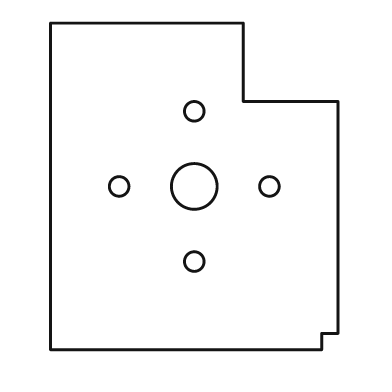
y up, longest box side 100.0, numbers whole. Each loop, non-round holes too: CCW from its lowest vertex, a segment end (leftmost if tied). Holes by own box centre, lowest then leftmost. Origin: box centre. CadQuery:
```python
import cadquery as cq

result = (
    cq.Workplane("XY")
    .moveTo(-44.0, -50.0)
    .lineTo(39.0, -50.0)
    .lineTo(39.0, -45.0)
    .lineTo(44.0, -45.0)
    .lineTo(44.0, 26.0)
    .lineTo(15.0, 26.0)
    .lineTo(15.0, 50.0)
    .lineTo(-44.0, 50.0)
    .close()
    .moveTo(0.0, -23.0)
    .circle(3.0)
    .moveTo(-23.0, 0.0)
    .circle(3.0)
    .moveTo(0.0, 0.0)
    .circle(7.0)
    .moveTo(23.0, 0.0)
    .circle(3.0)
    .moveTo(0.0, 23.0)
    .circle(3.0)
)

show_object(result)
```